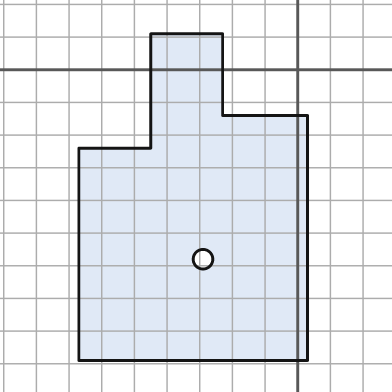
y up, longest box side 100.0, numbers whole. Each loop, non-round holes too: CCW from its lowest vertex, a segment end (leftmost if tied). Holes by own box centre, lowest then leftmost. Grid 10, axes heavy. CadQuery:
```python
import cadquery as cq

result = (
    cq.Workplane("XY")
    .moveTo(-67.0, -89.0)
    .lineTo(3.0, -89.0)
    .lineTo(3.0, -14.0)
    .lineTo(-23.0, -14.0)
    .lineTo(-23.0, 11.0)
    .lineTo(-45.0, 11.0)
    .lineTo(-45.0, -24.0)
    .lineTo(-67.0, -24.0)
    .close()
    .moveTo(-29.0, -58.0)
    .circle(3.0)
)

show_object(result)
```